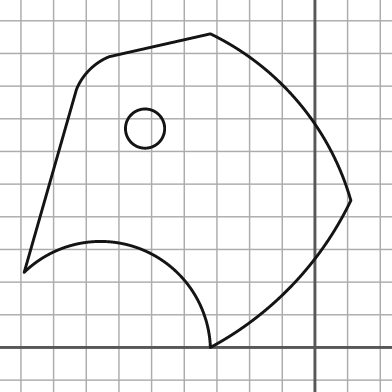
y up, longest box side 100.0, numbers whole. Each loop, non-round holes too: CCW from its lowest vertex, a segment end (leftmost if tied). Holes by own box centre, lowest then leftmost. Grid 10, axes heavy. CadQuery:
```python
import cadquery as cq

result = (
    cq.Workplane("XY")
    .moveTo(-32.0, 0.0)
    .threePointArc((-7.0, 19.0), (11.0, 45.0))
    .threePointArc((-5.0, 75.0), (-32.0, 96.0))
    .lineTo(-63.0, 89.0)
    .threePointArc((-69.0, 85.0), (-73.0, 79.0))
    .lineTo(-89.0, 23.0)
    .threePointArc((-53.0, 30.0), (-32.0, 0.0))
    .close()
    .moveTo(-52.0, 67.0)
    .circle(6.0)
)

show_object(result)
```